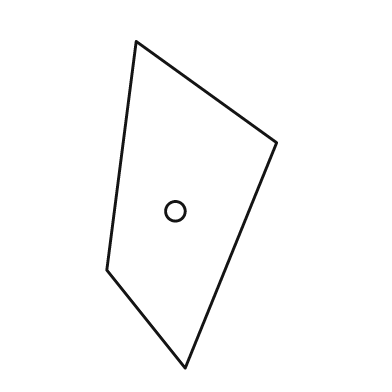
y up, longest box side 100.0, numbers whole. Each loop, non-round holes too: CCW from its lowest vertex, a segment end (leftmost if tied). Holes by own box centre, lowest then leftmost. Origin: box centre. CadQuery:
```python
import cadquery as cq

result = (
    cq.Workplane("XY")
    .moveTo(-2.0, -50.0)
    .lineTo(26.0, 19.0)
    .lineTo(-17.0, 50.0)
    .lineTo(-26.0, -20.0)
    .close()
    .moveTo(-5.0, -2.0)
    .circle(3.0)
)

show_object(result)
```